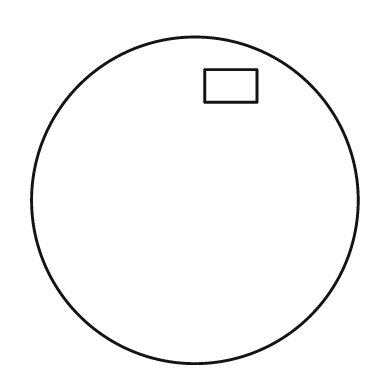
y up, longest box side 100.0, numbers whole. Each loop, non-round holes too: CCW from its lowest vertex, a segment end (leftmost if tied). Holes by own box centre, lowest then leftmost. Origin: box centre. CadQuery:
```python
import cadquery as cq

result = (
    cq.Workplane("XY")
    .moveTo(0.0, 0.0)
    .circle(50.0)
    .moveTo(3.0, 30.0)
    .lineTo(19.0, 30.0)
    .lineTo(19.0, 40.0)
    .lineTo(3.0, 40.0)
    .close()
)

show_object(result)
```